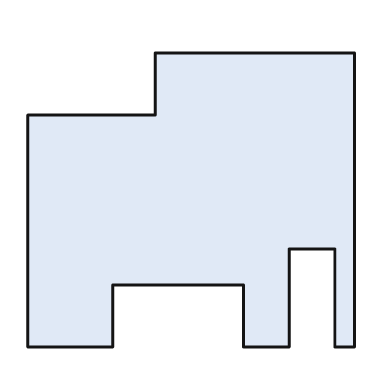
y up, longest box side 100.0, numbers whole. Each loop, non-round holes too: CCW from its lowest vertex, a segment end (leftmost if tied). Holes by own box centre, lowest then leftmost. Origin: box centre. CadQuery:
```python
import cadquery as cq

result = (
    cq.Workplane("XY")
    .moveTo(-50.0, -45.0)
    .lineTo(-24.0, -45.0)
    .lineTo(-24.0, -26.0)
    .lineTo(16.0, -26.0)
    .lineTo(16.0, -45.0)
    .lineTo(30.0, -45.0)
    .lineTo(30.0, -15.0)
    .lineTo(44.0, -15.0)
    .lineTo(44.0, -45.0)
    .lineTo(50.0, -45.0)
    .lineTo(50.0, 45.0)
    .lineTo(-11.0, 45.0)
    .lineTo(-11.0, 26.0)
    .lineTo(-50.0, 26.0)
    .close()
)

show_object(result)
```